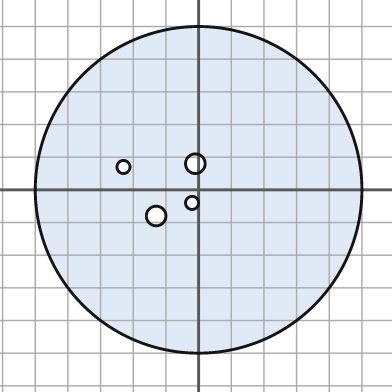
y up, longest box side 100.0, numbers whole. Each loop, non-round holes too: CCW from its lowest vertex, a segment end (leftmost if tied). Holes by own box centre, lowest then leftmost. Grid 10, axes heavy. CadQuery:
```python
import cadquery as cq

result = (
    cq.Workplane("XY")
    .moveTo(0.0, 0.0)
    .circle(50.0)
    .moveTo(-13.0, -8.0)
    .circle(3.0)
    .moveTo(-2.0, -4.0)
    .circle(2.0)
    .moveTo(-23.0, 7.0)
    .circle(2.0)
    .moveTo(-1.0, 8.0)
    .circle(3.0)
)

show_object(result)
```